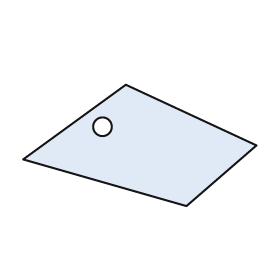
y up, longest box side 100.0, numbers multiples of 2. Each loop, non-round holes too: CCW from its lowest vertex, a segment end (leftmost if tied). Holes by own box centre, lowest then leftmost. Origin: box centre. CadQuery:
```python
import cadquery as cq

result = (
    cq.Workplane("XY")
    .moveTo(20.0, -26.0)
    .lineTo(50.0, 0.0)
    .lineTo(-6.0, 26.0)
    .lineTo(-50.0, -6.0)
    .close()
    .moveTo(-16.0, 8.0)
    .circle(4.0)
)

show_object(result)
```